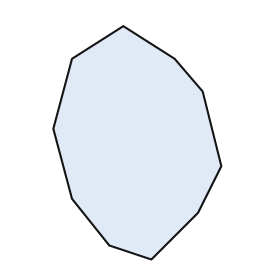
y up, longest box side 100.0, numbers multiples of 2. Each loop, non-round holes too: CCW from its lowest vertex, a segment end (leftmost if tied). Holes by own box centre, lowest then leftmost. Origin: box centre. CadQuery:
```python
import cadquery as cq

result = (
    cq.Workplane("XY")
    .moveTo(6.0, -50.0)
    .lineTo(26.0, -30.0)
    .lineTo(36.0, -10.0)
    .lineTo(28.0, 22.0)
    .lineTo(16.0, 36.0)
    .lineTo(-6.0, 50.0)
    .lineTo(-28.0, 36.0)
    .lineTo(-36.0, 6.0)
    .lineTo(-28.0, -24.0)
    .lineTo(-12.0, -44.0)
    .close()
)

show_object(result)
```